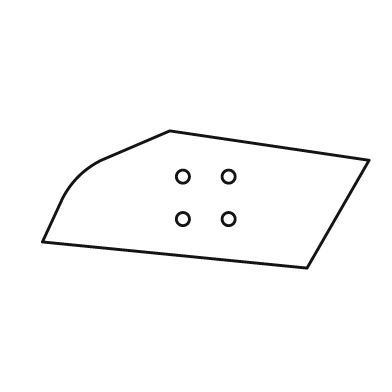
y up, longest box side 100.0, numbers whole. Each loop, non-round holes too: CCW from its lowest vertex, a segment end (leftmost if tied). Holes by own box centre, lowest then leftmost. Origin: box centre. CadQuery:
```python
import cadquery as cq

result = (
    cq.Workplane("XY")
    .moveTo(31.0, -21.0)
    .lineTo(50.0, 12.0)
    .lineTo(-11.0, 21.0)
    .lineTo(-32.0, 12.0)
    .threePointArc((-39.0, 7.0), (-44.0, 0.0))
    .lineTo(-50.0, -13.0)
    .close()
    .moveTo(-7.0, -6.0)
    .circle(2.0)
    .moveTo(7.0, -6.0)
    .circle(2.0)
    .moveTo(-7.0, 7.0)
    .circle(2.0)
    .moveTo(7.0, 7.0)
    .circle(2.0)
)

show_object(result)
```